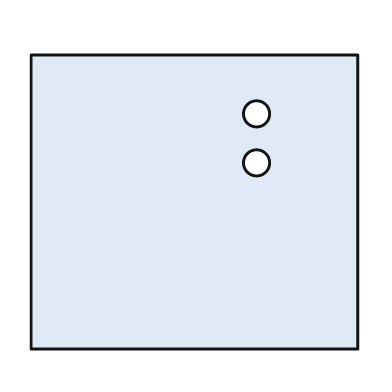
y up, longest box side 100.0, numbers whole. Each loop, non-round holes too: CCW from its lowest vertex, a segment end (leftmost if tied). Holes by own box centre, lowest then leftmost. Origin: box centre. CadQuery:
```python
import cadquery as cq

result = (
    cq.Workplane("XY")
    .moveTo(-50.0, -45.0)
    .lineTo(50.0, -45.0)
    .lineTo(50.0, 45.0)
    .lineTo(-50.0, 45.0)
    .close()
    .moveTo(19.0, 12.0)
    .circle(4.0)
    .moveTo(19.0, 27.0)
    .circle(4.0)
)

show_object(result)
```